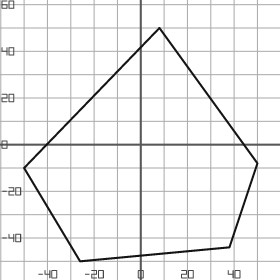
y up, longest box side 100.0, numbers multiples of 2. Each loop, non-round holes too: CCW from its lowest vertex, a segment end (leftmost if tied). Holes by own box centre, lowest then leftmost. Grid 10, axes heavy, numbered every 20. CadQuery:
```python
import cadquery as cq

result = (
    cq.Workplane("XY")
    .moveTo(-26.0, -50.0)
    .lineTo(38.0, -44.0)
    .lineTo(50.0, -8.0)
    .lineTo(8.0, 50.0)
    .lineTo(-50.0, -10.0)
    .close()
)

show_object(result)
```